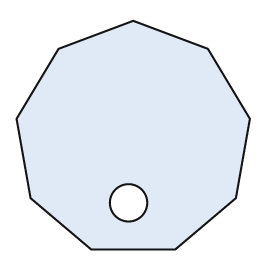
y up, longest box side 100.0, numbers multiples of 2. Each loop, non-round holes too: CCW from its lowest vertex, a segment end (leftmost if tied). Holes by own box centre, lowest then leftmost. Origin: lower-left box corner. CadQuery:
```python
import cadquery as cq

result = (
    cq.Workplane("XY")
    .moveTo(32.0, 0.0)
    .lineTo(68.0, 0.0)
    .lineTo(94.0, 22.0)
    .lineTo(100.0, 56.0)
    .lineTo(82.0, 86.0)
    .lineTo(50.0, 98.0)
    .lineTo(18.0, 86.0)
    .lineTo(0.0, 56.0)
    .lineTo(6.0, 22.0)
    .close()
    .moveTo(48.0, 20.0)
    .circle(8.0)
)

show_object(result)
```